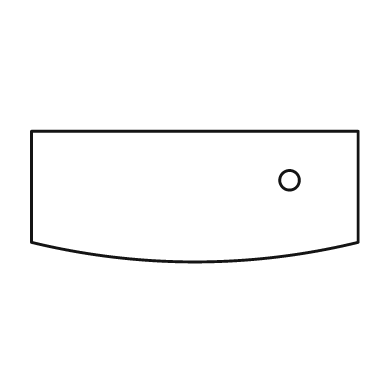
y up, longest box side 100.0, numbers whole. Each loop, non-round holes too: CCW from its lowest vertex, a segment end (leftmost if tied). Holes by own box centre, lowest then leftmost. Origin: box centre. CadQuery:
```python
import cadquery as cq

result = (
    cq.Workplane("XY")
    .moveTo(-50.0, -14.0)
    .threePointArc((0.0, -20.0), (50.0, -14.0))
    .lineTo(50.0, 20.0)
    .lineTo(-50.0, 20.0)
    .close()
    .moveTo(29.0, 5.0)
    .circle(3.0)
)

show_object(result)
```